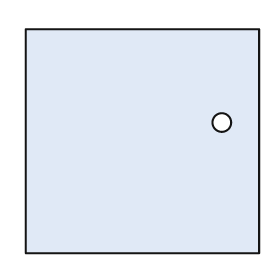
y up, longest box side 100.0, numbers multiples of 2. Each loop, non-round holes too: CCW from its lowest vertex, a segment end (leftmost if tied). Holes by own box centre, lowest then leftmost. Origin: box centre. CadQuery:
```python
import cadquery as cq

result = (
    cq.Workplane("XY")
    .moveTo(-50.0, -48.0)
    .lineTo(50.0, -48.0)
    .lineTo(50.0, 48.0)
    .lineTo(-50.0, 48.0)
    .close()
    .moveTo(34.0, 8.0)
    .circle(4.0)
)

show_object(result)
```